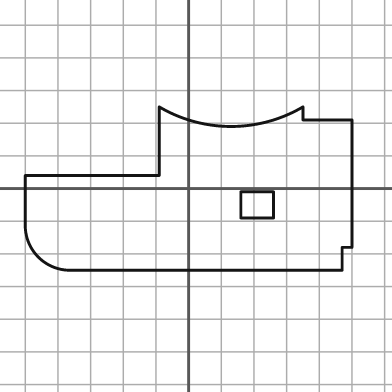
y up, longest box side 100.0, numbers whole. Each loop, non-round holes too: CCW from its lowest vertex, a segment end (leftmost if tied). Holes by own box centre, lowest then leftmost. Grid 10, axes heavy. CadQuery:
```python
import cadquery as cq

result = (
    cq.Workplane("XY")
    .moveTo(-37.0, -25.0)
    .lineTo(47.0, -25.0)
    .lineTo(47.0, -18.0)
    .lineTo(50.0, -18.0)
    .lineTo(50.0, 21.0)
    .lineTo(35.0, 21.0)
    .lineTo(35.0, 25.0)
    .threePointArc((13.0, 19.0), (-9.0, 25.0))
    .lineTo(-9.0, 4.0)
    .lineTo(-50.0, 4.0)
    .lineTo(-50.0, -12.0)
    .threePointArc((-46.0, -21.0), (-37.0, -25.0))
    .close()
    .moveTo(16.0, -9.0)
    .lineTo(26.0, -9.0)
    .lineTo(26.0, -1.0)
    .lineTo(16.0, -1.0)
    .close()
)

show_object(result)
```